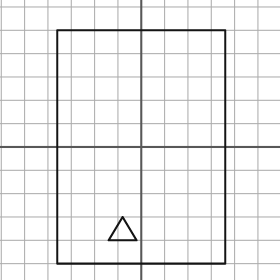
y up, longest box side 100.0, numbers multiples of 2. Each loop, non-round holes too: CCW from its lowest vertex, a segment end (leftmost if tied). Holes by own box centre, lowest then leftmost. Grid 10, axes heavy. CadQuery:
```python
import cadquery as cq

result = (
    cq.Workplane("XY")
    .moveTo(-36.0, -50.0)
    .lineTo(36.0, -50.0)
    .lineTo(36.0, 50.0)
    .lineTo(-36.0, 50.0)
    .close()
    .moveTo(-14.0, -40.0)
    .lineTo(-2.0, -40.0)
    .lineTo(-8.0, -30.0)
    .close()
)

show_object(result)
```